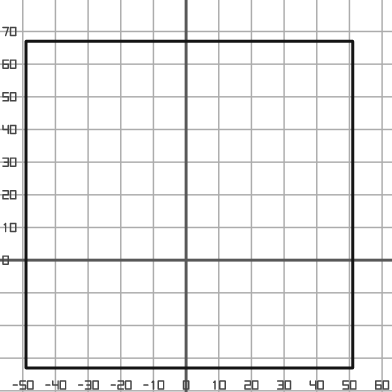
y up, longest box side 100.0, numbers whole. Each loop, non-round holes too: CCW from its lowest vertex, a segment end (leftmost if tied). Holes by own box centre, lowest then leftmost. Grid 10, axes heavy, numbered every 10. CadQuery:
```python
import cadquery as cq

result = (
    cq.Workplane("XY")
    .moveTo(-49.0, -33.0)
    .lineTo(51.0, -33.0)
    .lineTo(51.0, 67.0)
    .lineTo(-49.0, 67.0)
    .close()
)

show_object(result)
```